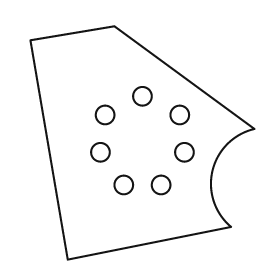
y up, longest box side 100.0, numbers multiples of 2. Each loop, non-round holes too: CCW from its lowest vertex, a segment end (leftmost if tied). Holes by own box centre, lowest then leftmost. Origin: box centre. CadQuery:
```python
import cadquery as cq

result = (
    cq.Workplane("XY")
    .moveTo(-32.0, -50.0)
    .lineTo(38.0, -36.0)
    .threePointArc((30.0, -12.0), (48.0, 6.0))
    .lineTo(-12.0, 50.0)
    .lineTo(-48.0, 44.0)
    .close()
    .moveTo(-8.0, -18.0)
    .circle(4.0)
    .moveTo(8.0, -18.0)
    .circle(4.0)
    .moveTo(-18.0, -4.0)
    .circle(4.0)
    .moveTo(18.0, -4.0)
    .circle(4.0)
    .moveTo(-16.0, 12.0)
    .circle(4.0)
    .moveTo(16.0, 12.0)
    .circle(4.0)
    .moveTo(0.0, 20.0)
    .circle(4.0)
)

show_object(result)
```